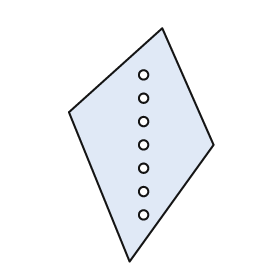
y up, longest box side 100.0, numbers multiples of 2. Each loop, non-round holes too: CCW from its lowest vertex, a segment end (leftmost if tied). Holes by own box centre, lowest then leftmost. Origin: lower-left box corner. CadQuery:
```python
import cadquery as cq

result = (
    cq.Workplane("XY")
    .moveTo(26.0, 0.0)
    .lineTo(62.0, 50.0)
    .lineTo(40.0, 100.0)
    .lineTo(0.0, 64.0)
    .close()
    .moveTo(32.0, 20.0)
    .circle(2.0)
    .moveTo(32.0, 30.0)
    .circle(2.0)
    .moveTo(32.0, 40.0)
    .circle(2.0)
    .moveTo(32.0, 50.0)
    .circle(2.0)
    .moveTo(32.0, 60.0)
    .circle(2.0)
    .moveTo(32.0, 70.0)
    .circle(2.0)
    .moveTo(32.0, 80.0)
    .circle(2.0)
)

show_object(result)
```